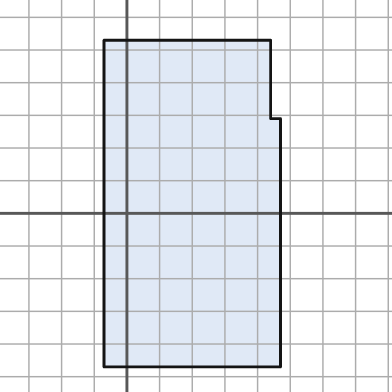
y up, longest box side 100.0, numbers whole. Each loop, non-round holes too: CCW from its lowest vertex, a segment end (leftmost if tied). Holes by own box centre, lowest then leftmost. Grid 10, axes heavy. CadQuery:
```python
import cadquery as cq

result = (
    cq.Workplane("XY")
    .moveTo(-7.0, -47.0)
    .lineTo(47.0, -47.0)
    .lineTo(47.0, 29.0)
    .lineTo(44.0, 29.0)
    .lineTo(44.0, 53.0)
    .lineTo(-7.0, 53.0)
    .close()
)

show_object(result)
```